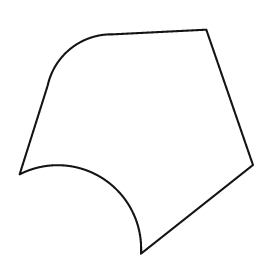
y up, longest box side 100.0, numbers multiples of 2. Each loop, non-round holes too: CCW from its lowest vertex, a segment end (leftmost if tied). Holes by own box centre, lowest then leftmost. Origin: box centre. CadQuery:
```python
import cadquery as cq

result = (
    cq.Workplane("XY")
    .moveTo(2.0, -48.0)
    .lineTo(50.0, -10.0)
    .lineTo(30.0, 48.0)
    .lineTo(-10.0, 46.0)
    .threePointArc((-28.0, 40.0), (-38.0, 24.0))
    .lineTo(-50.0, -14.0)
    .threePointArc((-14.0, -16.0), (2.0, -48.0))
    .close()
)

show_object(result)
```